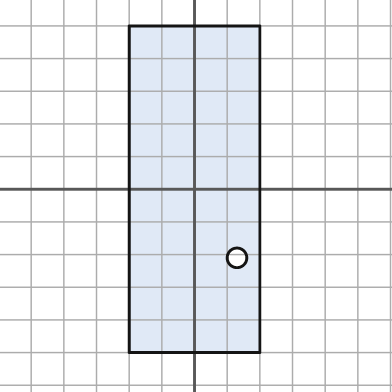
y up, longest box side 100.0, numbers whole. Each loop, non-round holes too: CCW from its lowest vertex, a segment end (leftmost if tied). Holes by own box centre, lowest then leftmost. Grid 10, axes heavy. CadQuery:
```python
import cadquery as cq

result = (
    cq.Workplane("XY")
    .moveTo(-20.0, -50.0)
    .lineTo(20.0, -50.0)
    .lineTo(20.0, 50.0)
    .lineTo(-20.0, 50.0)
    .close()
    .moveTo(13.0, -21.0)
    .circle(3.0)
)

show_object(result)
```